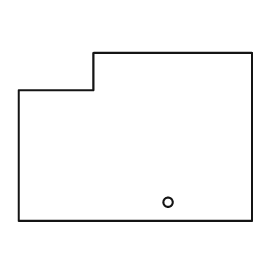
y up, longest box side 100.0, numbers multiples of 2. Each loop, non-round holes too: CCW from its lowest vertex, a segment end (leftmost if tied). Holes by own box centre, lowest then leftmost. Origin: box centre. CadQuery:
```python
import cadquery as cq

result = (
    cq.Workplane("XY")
    .moveTo(-50.0, -36.0)
    .lineTo(50.0, -36.0)
    .lineTo(50.0, 36.0)
    .lineTo(-18.0, 36.0)
    .lineTo(-18.0, 20.0)
    .lineTo(-50.0, 20.0)
    .close()
    .moveTo(14.0, -28.0)
    .circle(2.0)
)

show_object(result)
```